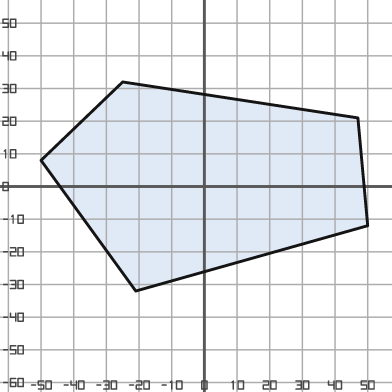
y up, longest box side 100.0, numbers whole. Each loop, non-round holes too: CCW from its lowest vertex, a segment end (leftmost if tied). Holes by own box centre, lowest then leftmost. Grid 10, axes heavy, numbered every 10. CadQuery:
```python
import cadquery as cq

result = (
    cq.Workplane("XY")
    .moveTo(-21.0, -32.0)
    .lineTo(50.0, -12.0)
    .lineTo(47.0, 21.0)
    .lineTo(-25.0, 32.0)
    .lineTo(-50.0, 8.0)
    .close()
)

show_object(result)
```